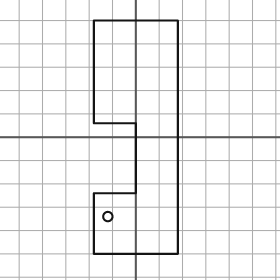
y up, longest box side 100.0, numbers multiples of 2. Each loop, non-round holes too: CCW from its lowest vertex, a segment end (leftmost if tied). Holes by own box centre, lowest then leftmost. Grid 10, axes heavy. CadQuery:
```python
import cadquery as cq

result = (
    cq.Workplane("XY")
    .moveTo(-18.0, -50.0)
    .lineTo(18.0, -50.0)
    .lineTo(18.0, 50.0)
    .lineTo(-18.0, 50.0)
    .lineTo(-18.0, 6.0)
    .lineTo(0.0, 6.0)
    .lineTo(0.0, -24.0)
    .lineTo(-18.0, -24.0)
    .close()
    .moveTo(-12.0, -34.0)
    .circle(2.0)
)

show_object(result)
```